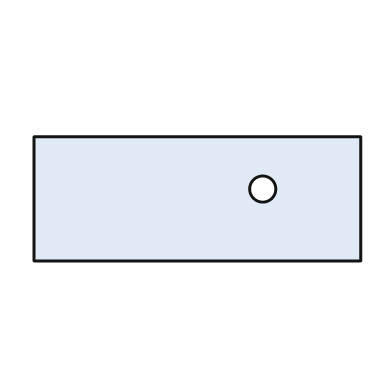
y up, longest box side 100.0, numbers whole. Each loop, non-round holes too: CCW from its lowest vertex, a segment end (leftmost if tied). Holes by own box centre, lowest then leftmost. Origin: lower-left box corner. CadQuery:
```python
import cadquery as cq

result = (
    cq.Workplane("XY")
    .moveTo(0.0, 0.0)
    .lineTo(100.0, 0.0)
    .lineTo(100.0, 38.0)
    .lineTo(0.0, 38.0)
    .close()
    .moveTo(70.0, 22.0)
    .circle(4.0)
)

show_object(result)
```